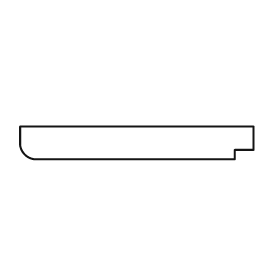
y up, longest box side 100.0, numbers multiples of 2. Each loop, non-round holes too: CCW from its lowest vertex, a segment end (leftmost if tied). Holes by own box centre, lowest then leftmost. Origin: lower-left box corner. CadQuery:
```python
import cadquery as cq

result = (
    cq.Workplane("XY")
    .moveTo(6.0, 0.0)
    .lineTo(92.0, 0.0)
    .lineTo(92.0, 4.0)
    .lineTo(100.0, 4.0)
    .lineTo(100.0, 14.0)
    .lineTo(0.0, 14.0)
    .lineTo(0.0, 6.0)
    .threePointArc((2.0, 2.0), (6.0, 0.0))
    .close()
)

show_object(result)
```